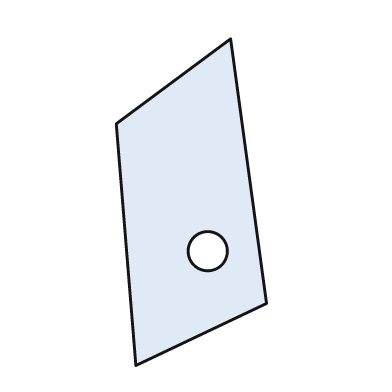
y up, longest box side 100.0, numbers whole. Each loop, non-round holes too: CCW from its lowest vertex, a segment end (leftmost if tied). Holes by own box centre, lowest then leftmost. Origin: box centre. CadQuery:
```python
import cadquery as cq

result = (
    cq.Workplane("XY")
    .moveTo(-17.0, -50.0)
    .lineTo(23.0, -31.0)
    .lineTo(12.0, 50.0)
    .lineTo(-23.0, 24.0)
    .close()
    .moveTo(5.0, -15.0)
    .circle(6.0)
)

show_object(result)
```